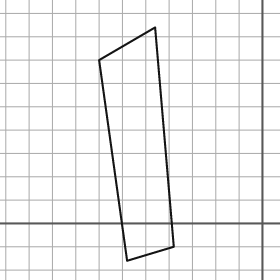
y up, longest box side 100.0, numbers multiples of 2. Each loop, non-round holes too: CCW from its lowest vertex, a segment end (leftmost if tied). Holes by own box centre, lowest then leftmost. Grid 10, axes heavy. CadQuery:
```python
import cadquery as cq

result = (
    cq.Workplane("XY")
    .moveTo(-58.0, -16.0)
    .lineTo(-38.0, -10.0)
    .lineTo(-46.0, 84.0)
    .lineTo(-70.0, 70.0)
    .close()
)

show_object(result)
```